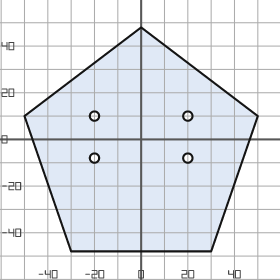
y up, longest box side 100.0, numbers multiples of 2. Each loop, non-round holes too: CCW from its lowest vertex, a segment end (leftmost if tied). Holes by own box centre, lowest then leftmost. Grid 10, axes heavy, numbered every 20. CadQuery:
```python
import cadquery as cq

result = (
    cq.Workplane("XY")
    .moveTo(-30.0, -48.0)
    .lineTo(30.0, -48.0)
    .lineTo(50.0, 10.0)
    .lineTo(0.0, 48.0)
    .lineTo(-50.0, 10.0)
    .close()
    .moveTo(-20.0, -8.0)
    .circle(2.0)
    .moveTo(20.0, -8.0)
    .circle(2.0)
    .moveTo(-20.0, 10.0)
    .circle(2.0)
    .moveTo(20.0, 10.0)
    .circle(2.0)
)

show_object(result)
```